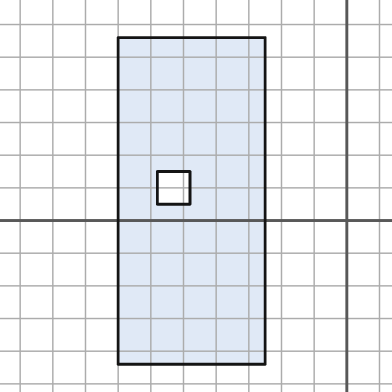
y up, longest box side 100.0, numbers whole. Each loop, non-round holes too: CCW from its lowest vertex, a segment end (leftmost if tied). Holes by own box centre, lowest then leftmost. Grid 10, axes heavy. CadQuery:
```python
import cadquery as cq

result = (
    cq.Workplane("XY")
    .moveTo(-70.0, -44.0)
    .lineTo(-25.0, -44.0)
    .lineTo(-25.0, 56.0)
    .lineTo(-70.0, 56.0)
    .close()
    .moveTo(-58.0, 5.0)
    .lineTo(-48.0, 5.0)
    .lineTo(-48.0, 15.0)
    .lineTo(-58.0, 15.0)
    .close()
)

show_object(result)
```